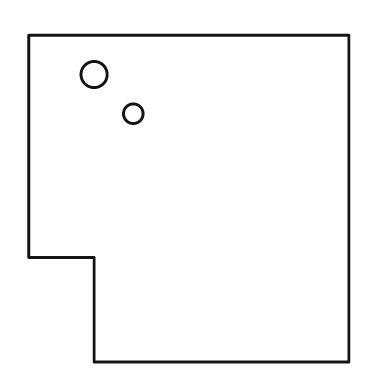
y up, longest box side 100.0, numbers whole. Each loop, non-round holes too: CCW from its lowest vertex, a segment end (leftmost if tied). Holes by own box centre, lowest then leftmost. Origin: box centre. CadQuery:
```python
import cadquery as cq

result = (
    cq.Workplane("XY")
    .moveTo(-29.0, -50.0)
    .lineTo(49.0, -50.0)
    .lineTo(49.0, 50.0)
    .lineTo(-49.0, 50.0)
    .lineTo(-49.0, -18.0)
    .lineTo(-29.0, -18.0)
    .close()
    .moveTo(-17.0, 26.0)
    .circle(3.0)
    .moveTo(-29.0, 38.0)
    .circle(4.0)
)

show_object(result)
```